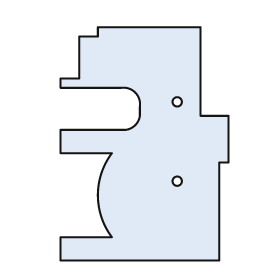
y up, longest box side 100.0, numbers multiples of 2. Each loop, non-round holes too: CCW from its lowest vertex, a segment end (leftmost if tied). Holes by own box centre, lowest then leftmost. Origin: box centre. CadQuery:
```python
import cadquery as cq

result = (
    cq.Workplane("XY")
    .moveTo(-36.0, -50.0)
    .lineTo(32.0, -50.0)
    .lineTo(32.0, -8.0)
    .lineTo(36.0, -8.0)
    .lineTo(36.0, 12.0)
    .lineTo(24.0, 12.0)
    .lineTo(24.0, 50.0)
    .lineTo(-20.0, 50.0)
    .lineTo(-20.0, 46.0)
    .lineTo(-28.0, 46.0)
    .lineTo(-28.0, 28.0)
    .lineTo(-36.0, 28.0)
    .lineTo(-36.0, 24.0)
    .lineTo(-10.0, 24.0)
    .threePointArc((-4.0, 22.0), (-2.0, 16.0))
    .lineTo(-2.0, 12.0)
    .threePointArc((-4.0, 8.0), (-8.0, 6.0))
    .lineTo(-36.0, 6.0)
    .lineTo(-36.0, -4.0)
    .lineTo(-14.0, -4.0)
    .threePointArc((-20.0, -22.0), (-14.0, -40.0))
    .lineTo(-36.0, -40.0)
    .close()
    .moveTo(14.0, -16.0)
    .circle(2.0)
    .moveTo(14.0, 18.0)
    .circle(2.0)
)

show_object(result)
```